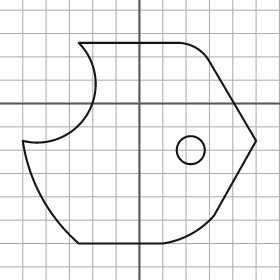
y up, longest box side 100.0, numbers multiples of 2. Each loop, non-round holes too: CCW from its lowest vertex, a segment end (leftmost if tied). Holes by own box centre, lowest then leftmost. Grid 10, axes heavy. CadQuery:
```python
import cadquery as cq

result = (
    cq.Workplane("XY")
    .moveTo(-26.0, -60.0)
    .lineTo(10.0, -60.0)
    .threePointArc((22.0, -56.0), (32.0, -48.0))
    .lineTo(50.0, -16.0)
    .lineTo(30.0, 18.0)
    .threePointArc((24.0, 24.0), (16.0, 26.0))
    .lineTo(-26.0, 26.0)
    .threePointArc((-22.0, -4.0), (-50.0, -16.0))
    .threePointArc((-42.0, -40.0), (-26.0, -60.0))
    .close()
    .moveTo(22.0, -20.0)
    .circle(6.0)
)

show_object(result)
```